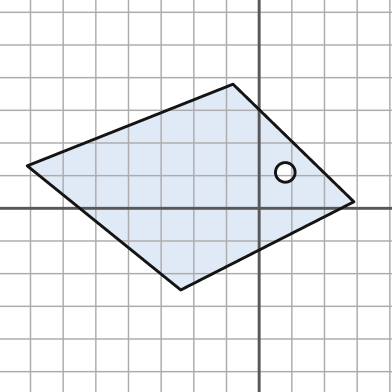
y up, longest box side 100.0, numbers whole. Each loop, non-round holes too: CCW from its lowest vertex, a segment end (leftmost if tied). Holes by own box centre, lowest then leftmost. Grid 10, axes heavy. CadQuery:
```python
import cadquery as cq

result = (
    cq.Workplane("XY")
    .moveTo(-24.0, -25.0)
    .lineTo(29.0, 2.0)
    .lineTo(-8.0, 38.0)
    .lineTo(-71.0, 13.0)
    .close()
    .moveTo(8.0, 11.0)
    .circle(3.0)
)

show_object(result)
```